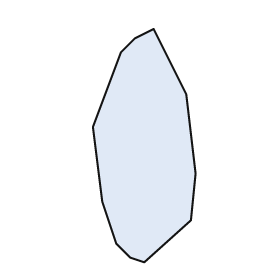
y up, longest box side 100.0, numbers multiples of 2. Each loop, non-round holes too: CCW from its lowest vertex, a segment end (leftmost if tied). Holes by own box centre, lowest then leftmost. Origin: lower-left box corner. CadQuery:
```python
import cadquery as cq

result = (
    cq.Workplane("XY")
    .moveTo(22.0, 0.0)
    .lineTo(42.0, 18.0)
    .lineTo(44.0, 38.0)
    .lineTo(40.0, 72.0)
    .lineTo(26.0, 100.0)
    .lineTo(18.0, 96.0)
    .lineTo(12.0, 90.0)
    .lineTo(0.0, 58.0)
    .lineTo(4.0, 26.0)
    .lineTo(10.0, 8.0)
    .lineTo(16.0, 2.0)
    .close()
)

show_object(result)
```